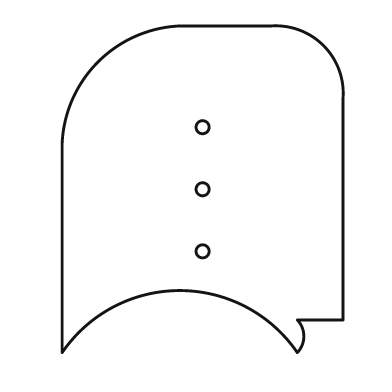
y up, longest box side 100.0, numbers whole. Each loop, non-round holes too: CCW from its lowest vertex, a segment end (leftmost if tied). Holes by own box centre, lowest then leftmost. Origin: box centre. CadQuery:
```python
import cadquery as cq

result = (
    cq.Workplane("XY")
    .moveTo(-43.0, -50.0)
    .threePointArc((-7.0, -31.0), (29.0, -50.0))
    .threePointArc((31.0, -45.0), (29.0, -40.0))
    .lineTo(43.0, -40.0)
    .lineTo(43.0, 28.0)
    .threePointArc((37.0, 44.0), (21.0, 50.0))
    .lineTo(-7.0, 50.0)
    .threePointArc((-32.0, 39.0), (-43.0, 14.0))
    .close()
    .moveTo(0.0, -19.0)
    .circle(2.0)
    .moveTo(0.0, 0.0)
    .circle(2.0)
    .moveTo(0.0, 19.0)
    .circle(2.0)
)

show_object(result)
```